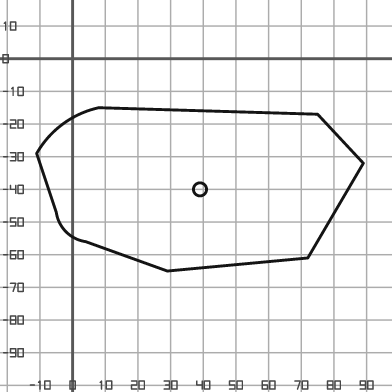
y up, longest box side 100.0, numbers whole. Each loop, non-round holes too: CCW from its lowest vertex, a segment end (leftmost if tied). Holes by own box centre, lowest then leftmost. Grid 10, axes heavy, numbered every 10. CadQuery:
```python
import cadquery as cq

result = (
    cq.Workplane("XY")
    .moveTo(29.0, -65.0)
    .lineTo(72.0, -61.0)
    .lineTo(89.0, -32.0)
    .lineTo(75.0, -17.0)
    .lineTo(8.0, -15.0)
    .threePointArc((-3.0, -20.0), (-11.0, -29.0))
    .lineTo(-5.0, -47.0)
    .threePointArc((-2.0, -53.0), (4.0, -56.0))
    .close()
    .moveTo(39.0, -40.0)
    .circle(2.0)
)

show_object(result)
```